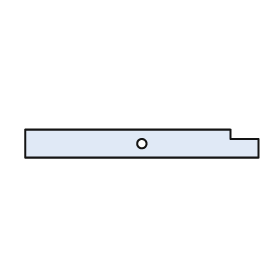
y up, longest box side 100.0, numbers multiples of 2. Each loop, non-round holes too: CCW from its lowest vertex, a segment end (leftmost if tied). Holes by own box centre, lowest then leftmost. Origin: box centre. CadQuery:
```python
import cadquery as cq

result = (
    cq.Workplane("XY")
    .moveTo(-50.0, -6.0)
    .lineTo(50.0, -6.0)
    .lineTo(50.0, 2.0)
    .lineTo(38.0, 2.0)
    .lineTo(38.0, 6.0)
    .lineTo(-50.0, 6.0)
    .close()
    .moveTo(0.0, 0.0)
    .circle(2.0)
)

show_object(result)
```